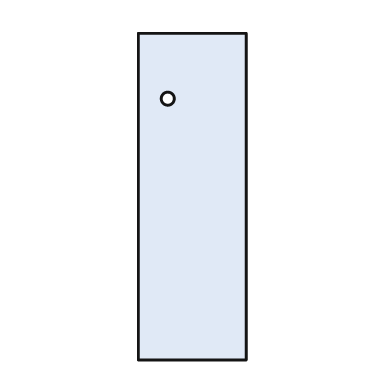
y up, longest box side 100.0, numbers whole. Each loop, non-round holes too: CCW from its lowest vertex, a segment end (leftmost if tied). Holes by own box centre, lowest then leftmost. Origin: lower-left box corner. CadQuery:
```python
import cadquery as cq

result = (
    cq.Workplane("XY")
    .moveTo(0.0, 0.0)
    .lineTo(33.0, 0.0)
    .lineTo(33.0, 100.0)
    .lineTo(0.0, 100.0)
    .close()
    .moveTo(9.0, 80.0)
    .circle(2.0)
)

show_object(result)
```